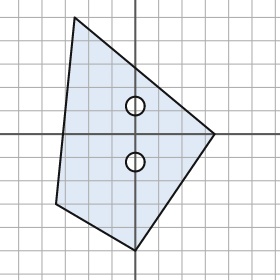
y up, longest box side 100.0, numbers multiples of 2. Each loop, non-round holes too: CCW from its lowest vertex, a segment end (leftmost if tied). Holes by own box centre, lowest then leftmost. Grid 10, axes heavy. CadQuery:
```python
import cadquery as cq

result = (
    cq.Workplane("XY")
    .moveTo(0.0, -50.0)
    .lineTo(34.0, 0.0)
    .lineTo(-26.0, 50.0)
    .lineTo(-34.0, -30.0)
    .close()
    .moveTo(0.0, -12.0)
    .circle(4.0)
    .moveTo(0.0, 12.0)
    .circle(4.0)
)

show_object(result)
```